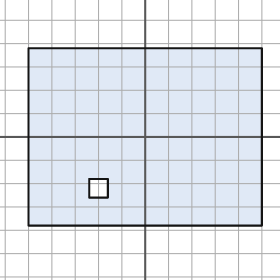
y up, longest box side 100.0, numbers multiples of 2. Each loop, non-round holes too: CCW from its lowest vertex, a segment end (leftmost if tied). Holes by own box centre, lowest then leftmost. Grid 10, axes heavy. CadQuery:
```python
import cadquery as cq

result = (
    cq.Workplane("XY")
    .moveTo(-50.0, -38.0)
    .lineTo(50.0, -38.0)
    .lineTo(50.0, 38.0)
    .lineTo(-50.0, 38.0)
    .close()
    .moveTo(-24.0, -26.0)
    .lineTo(-16.0, -26.0)
    .lineTo(-16.0, -18.0)
    .lineTo(-24.0, -18.0)
    .close()
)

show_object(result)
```